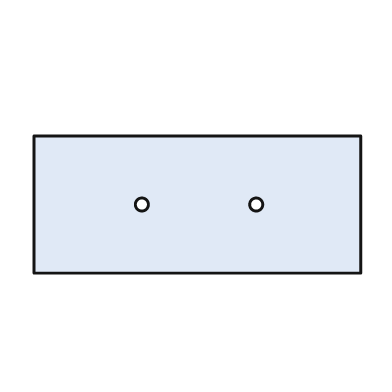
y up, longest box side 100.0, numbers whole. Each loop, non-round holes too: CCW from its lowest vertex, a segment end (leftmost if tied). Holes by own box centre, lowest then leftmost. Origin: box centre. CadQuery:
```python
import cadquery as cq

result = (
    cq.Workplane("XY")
    .moveTo(-50.0, -21.0)
    .lineTo(50.0, -21.0)
    .lineTo(50.0, 21.0)
    .lineTo(-50.0, 21.0)
    .close()
    .moveTo(-17.0, 0.0)
    .circle(2.0)
    .moveTo(18.0, 0.0)
    .circle(2.0)
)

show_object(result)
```